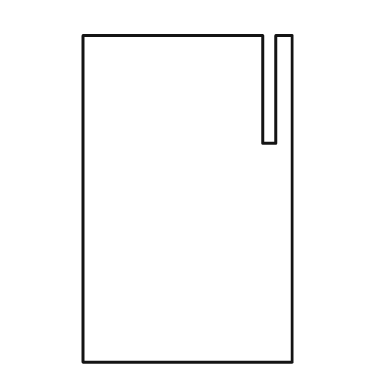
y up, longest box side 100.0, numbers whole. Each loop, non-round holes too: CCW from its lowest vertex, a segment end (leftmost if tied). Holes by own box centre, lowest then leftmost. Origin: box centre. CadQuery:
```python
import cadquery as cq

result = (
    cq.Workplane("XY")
    .moveTo(-32.0, -50.0)
    .lineTo(32.0, -50.0)
    .lineTo(32.0, 50.0)
    .lineTo(27.0, 50.0)
    .lineTo(27.0, 17.0)
    .lineTo(23.0, 17.0)
    .lineTo(23.0, 50.0)
    .lineTo(-32.0, 50.0)
    .close()
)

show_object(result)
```